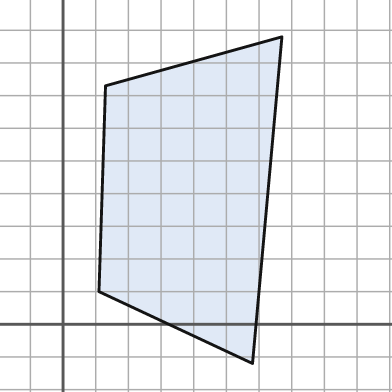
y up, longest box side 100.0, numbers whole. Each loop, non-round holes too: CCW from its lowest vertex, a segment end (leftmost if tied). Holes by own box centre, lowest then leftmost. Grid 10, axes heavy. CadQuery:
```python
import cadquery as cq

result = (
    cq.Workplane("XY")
    .moveTo(58.0, -12.0)
    .lineTo(67.0, 88.0)
    .lineTo(13.0, 73.0)
    .lineTo(11.0, 10.0)
    .close()
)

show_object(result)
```